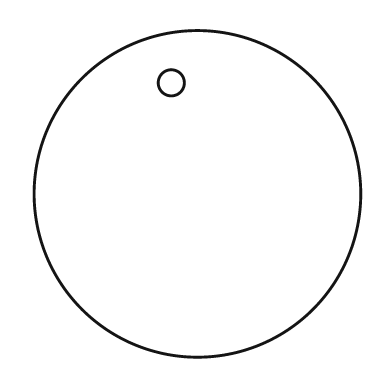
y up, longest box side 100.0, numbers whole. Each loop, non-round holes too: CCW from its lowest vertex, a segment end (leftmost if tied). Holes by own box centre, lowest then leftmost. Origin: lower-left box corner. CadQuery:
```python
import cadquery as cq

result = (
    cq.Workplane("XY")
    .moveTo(50.0, 50.0)
    .circle(50.0)
    .moveTo(42.0, 84.0)
    .circle(4.0)
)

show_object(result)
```